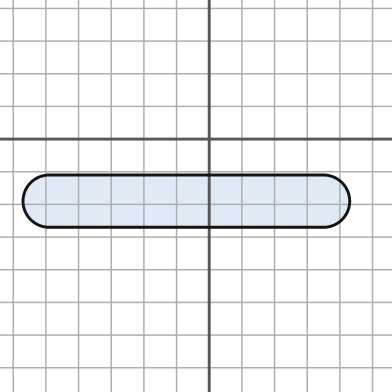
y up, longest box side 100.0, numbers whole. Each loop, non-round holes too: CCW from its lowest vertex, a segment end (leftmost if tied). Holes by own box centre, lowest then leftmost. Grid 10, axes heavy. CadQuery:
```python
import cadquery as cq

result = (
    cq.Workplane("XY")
    .moveTo(-49.0, -27.0)
    .lineTo(35.0, -27.0)
    .threePointArc((43.0, -19.0), (35.0, -11.0))
    .lineTo(-49.0, -11.0)
    .threePointArc((-57.0, -19.0), (-49.0, -27.0))
    .close()
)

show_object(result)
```